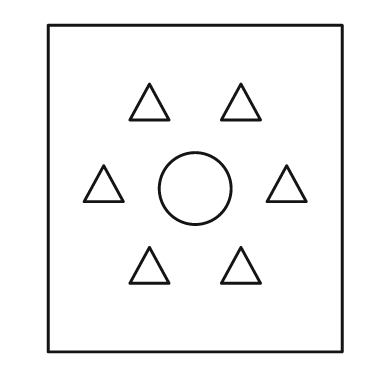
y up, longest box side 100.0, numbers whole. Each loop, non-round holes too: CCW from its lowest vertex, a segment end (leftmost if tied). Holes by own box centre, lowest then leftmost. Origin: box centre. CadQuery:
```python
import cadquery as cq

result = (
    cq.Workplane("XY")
    .moveTo(-45.0, -50.0)
    .lineTo(45.0, -50.0)
    .lineTo(45.0, 50.0)
    .lineTo(-45.0, 50.0)
    .close()
    .moveTo(-20.0, -29.0)
    .lineTo(-8.0, -29.0)
    .lineTo(-14.0, -18.0)
    .close()
    .moveTo(8.0, -29.0)
    .lineTo(20.0, -29.0)
    .lineTo(14.0, -18.0)
    .close()
    .moveTo(0.0, 0.0)
    .circle(11.0)
    .moveTo(-34.0, -4.0)
    .lineTo(-22.0, -4.0)
    .lineTo(-28.0, 7.0)
    .close()
    .moveTo(22.0, -4.0)
    .lineTo(34.0, -4.0)
    .lineTo(28.0, 7.0)
    .close()
    .moveTo(-20.0, 21.0)
    .lineTo(-8.0, 21.0)
    .lineTo(-14.0, 32.0)
    .close()
    .moveTo(8.0, 21.0)
    .lineTo(20.0, 21.0)
    .lineTo(14.0, 32.0)
    .close()
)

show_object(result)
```